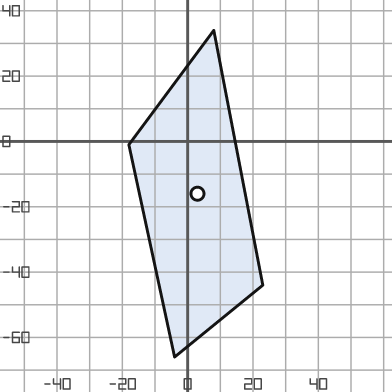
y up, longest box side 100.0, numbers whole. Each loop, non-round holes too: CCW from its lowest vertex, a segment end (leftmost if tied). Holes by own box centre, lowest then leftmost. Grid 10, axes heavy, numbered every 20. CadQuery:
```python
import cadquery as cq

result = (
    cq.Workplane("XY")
    .moveTo(-4.0, -66.0)
    .lineTo(23.0, -44.0)
    .lineTo(8.0, 34.0)
    .lineTo(-18.0, -1.0)
    .close()
    .moveTo(3.0, -16.0)
    .circle(2.0)
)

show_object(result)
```